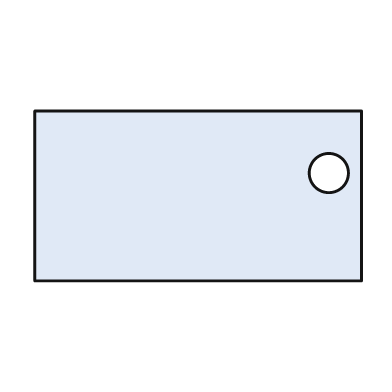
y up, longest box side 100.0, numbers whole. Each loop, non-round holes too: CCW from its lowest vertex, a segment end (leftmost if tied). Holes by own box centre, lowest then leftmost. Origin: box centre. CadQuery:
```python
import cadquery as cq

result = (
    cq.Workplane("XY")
    .moveTo(-50.0, -26.0)
    .lineTo(50.0, -26.0)
    .lineTo(50.0, 26.0)
    .lineTo(-50.0, 26.0)
    .close()
    .moveTo(40.0, 7.0)
    .circle(6.0)
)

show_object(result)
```